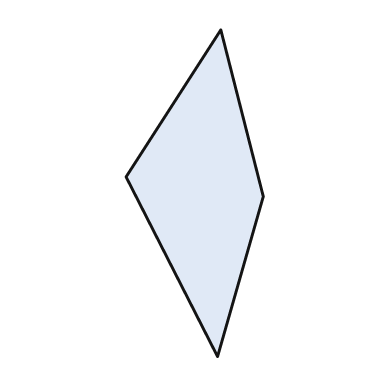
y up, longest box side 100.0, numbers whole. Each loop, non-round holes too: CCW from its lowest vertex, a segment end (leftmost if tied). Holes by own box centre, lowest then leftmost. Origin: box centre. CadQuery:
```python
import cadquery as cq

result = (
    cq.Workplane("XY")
    .moveTo(7.0, -50.0)
    .lineTo(21.0, -1.0)
    .lineTo(8.0, 50.0)
    .lineTo(-21.0, 5.0)
    .close()
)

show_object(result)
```